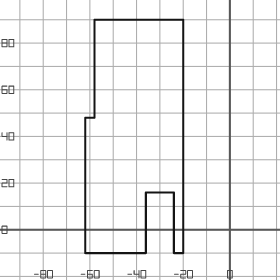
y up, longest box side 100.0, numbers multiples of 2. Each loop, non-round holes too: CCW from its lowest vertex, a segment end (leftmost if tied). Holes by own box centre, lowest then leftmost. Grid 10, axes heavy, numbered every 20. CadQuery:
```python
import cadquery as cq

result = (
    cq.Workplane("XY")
    .moveTo(-62.0, -10.0)
    .lineTo(-36.0, -10.0)
    .lineTo(-36.0, 16.0)
    .lineTo(-24.0, 16.0)
    .lineTo(-24.0, -10.0)
    .lineTo(-20.0, -10.0)
    .lineTo(-20.0, 90.0)
    .lineTo(-58.0, 90.0)
    .lineTo(-58.0, 48.0)
    .lineTo(-62.0, 48.0)
    .close()
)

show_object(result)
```